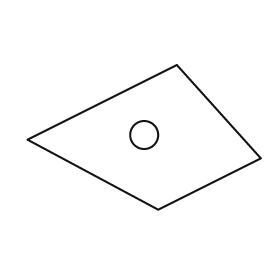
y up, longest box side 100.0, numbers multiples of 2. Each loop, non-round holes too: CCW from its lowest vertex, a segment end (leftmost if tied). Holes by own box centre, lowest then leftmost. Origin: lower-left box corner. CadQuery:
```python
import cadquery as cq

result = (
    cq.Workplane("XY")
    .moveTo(56.0, 0.0)
    .lineTo(100.0, 22.0)
    .lineTo(64.0, 62.0)
    .lineTo(0.0, 30.0)
    .close()
    .moveTo(50.0, 32.0)
    .circle(6.0)
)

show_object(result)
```